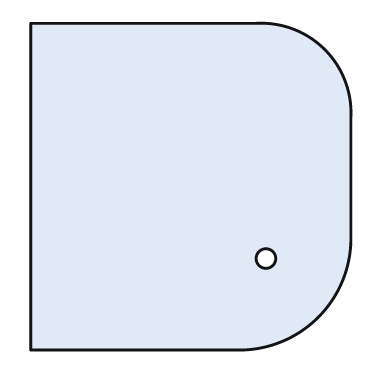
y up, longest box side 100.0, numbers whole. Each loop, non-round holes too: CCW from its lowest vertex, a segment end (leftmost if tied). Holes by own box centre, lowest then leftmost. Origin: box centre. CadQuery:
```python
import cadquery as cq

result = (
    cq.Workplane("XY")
    .moveTo(-49.0, -50.0)
    .lineTo(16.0, -50.0)
    .threePointArc((39.0, -40.0), (49.0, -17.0))
    .lineTo(49.0, 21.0)
    .threePointArc((41.0, 42.0), (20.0, 50.0))
    .lineTo(-49.0, 50.0)
    .close()
    .moveTo(23.0, -22.0)
    .circle(3.0)
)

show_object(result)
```